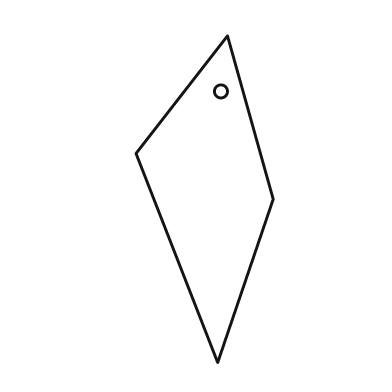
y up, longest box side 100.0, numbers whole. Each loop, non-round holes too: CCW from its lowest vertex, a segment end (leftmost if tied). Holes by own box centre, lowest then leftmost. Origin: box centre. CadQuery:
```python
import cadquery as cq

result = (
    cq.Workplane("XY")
    .moveTo(4.0, -50.0)
    .lineTo(21.0, 0.0)
    .lineTo(7.0, 50.0)
    .lineTo(-21.0, 14.0)
    .close()
    .moveTo(5.0, 33.0)
    .circle(2.0)
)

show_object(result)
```